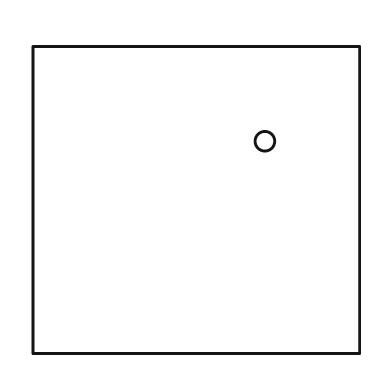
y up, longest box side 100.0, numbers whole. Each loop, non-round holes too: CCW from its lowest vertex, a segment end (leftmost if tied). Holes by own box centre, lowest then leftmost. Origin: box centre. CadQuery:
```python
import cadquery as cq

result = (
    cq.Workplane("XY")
    .moveTo(-50.0, -47.0)
    .lineTo(50.0, -47.0)
    .lineTo(50.0, 47.0)
    .lineTo(-50.0, 47.0)
    .close()
    .moveTo(21.0, 18.0)
    .circle(3.0)
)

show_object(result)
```